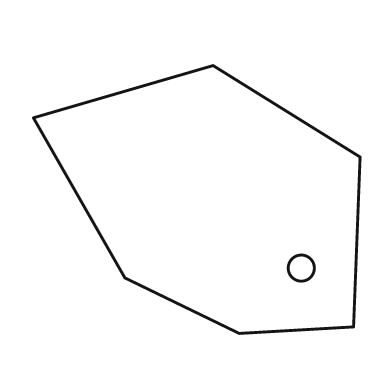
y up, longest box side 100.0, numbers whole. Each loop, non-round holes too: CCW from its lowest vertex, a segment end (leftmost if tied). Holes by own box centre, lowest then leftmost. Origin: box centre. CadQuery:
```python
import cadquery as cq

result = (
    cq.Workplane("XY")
    .moveTo(13.0, -41.0)
    .lineTo(48.0, -39.0)
    .lineTo(50.0, 13.0)
    .lineTo(5.0, 41.0)
    .lineTo(-50.0, 25.0)
    .lineTo(-22.0, -24.0)
    .close()
    .moveTo(32.0, -21.0)
    .circle(4.0)
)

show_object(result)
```